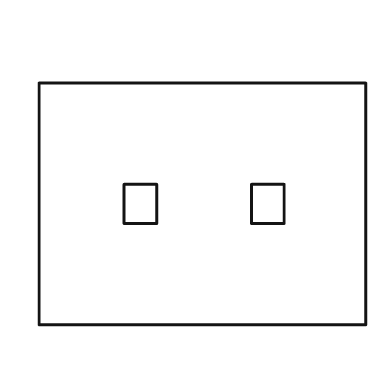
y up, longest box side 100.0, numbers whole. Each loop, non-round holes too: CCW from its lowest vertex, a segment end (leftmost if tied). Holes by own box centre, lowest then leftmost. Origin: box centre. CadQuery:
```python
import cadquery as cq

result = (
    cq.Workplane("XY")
    .moveTo(-50.0, -37.0)
    .lineTo(50.0, -37.0)
    .lineTo(50.0, 37.0)
    .lineTo(-50.0, 37.0)
    .close()
    .moveTo(-24.0, -6.0)
    .lineTo(-14.0, -6.0)
    .lineTo(-14.0, 6.0)
    .lineTo(-24.0, 6.0)
    .close()
    .moveTo(15.0, -6.0)
    .lineTo(25.0, -6.0)
    .lineTo(25.0, 6.0)
    .lineTo(15.0, 6.0)
    .close()
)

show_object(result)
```